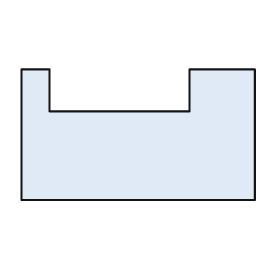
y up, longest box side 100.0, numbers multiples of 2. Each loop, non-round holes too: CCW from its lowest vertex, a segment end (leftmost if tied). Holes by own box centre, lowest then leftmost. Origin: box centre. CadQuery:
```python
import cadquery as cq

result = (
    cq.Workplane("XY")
    .moveTo(-50.0, -28.0)
    .lineTo(50.0, -28.0)
    .lineTo(50.0, 28.0)
    .lineTo(22.0, 28.0)
    .lineTo(22.0, 10.0)
    .lineTo(-38.0, 10.0)
    .lineTo(-38.0, 28.0)
    .lineTo(-50.0, 28.0)
    .close()
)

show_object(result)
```